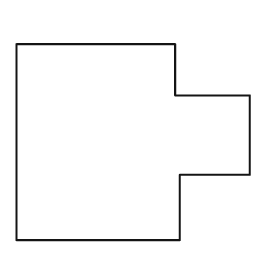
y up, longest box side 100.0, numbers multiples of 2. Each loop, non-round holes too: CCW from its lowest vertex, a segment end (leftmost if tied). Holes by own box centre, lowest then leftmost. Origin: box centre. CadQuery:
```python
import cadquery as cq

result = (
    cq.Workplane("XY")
    .moveTo(-50.0, -42.0)
    .lineTo(20.0, -42.0)
    .lineTo(20.0, -14.0)
    .lineTo(50.0, -14.0)
    .lineTo(50.0, 20.0)
    .lineTo(18.0, 20.0)
    .lineTo(18.0, 42.0)
    .lineTo(-50.0, 42.0)
    .close()
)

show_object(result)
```